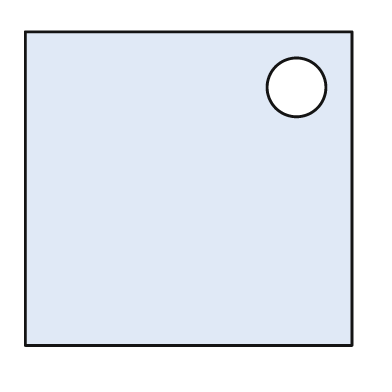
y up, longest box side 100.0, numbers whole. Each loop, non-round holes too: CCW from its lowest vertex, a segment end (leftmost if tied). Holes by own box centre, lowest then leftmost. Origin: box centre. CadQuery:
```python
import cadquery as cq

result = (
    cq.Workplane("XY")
    .moveTo(-50.0, -48.0)
    .lineTo(50.0, -48.0)
    .lineTo(50.0, 48.0)
    .lineTo(-50.0, 48.0)
    .close()
    .moveTo(33.0, 31.0)
    .circle(9.0)
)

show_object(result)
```